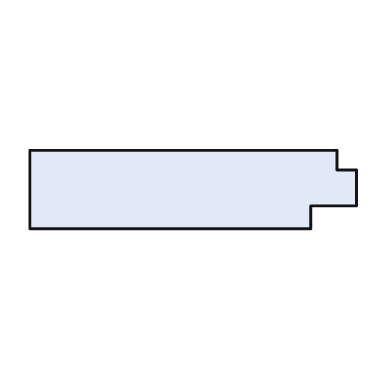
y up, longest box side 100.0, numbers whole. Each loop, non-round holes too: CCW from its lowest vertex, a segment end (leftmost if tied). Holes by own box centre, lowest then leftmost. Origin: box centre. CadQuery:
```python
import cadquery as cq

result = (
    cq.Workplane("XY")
    .moveTo(-50.0, -12.0)
    .lineTo(36.0, -12.0)
    .lineTo(36.0, -5.0)
    .lineTo(50.0, -5.0)
    .lineTo(50.0, 6.0)
    .lineTo(44.0, 6.0)
    .lineTo(44.0, 12.0)
    .lineTo(-50.0, 12.0)
    .close()
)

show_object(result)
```